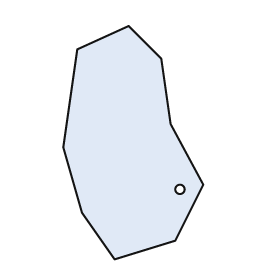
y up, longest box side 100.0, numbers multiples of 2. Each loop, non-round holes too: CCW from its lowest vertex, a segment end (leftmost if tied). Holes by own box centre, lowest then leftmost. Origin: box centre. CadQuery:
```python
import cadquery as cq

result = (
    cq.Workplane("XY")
    .moveTo(-8.0, -50.0)
    .lineTo(18.0, -42.0)
    .lineTo(30.0, -18.0)
    .lineTo(16.0, 8.0)
    .lineTo(12.0, 36.0)
    .lineTo(-2.0, 50.0)
    .lineTo(-24.0, 40.0)
    .lineTo(-30.0, -2.0)
    .lineTo(-22.0, -30.0)
    .close()
    .moveTo(20.0, -20.0)
    .circle(2.0)
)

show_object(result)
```